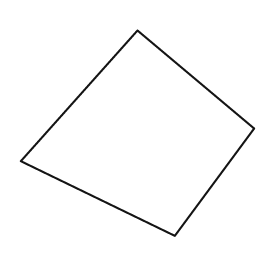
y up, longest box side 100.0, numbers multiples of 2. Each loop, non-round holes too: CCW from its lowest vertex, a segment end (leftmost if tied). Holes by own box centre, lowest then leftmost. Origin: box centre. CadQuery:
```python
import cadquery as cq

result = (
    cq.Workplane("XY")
    .moveTo(16.0, -44.0)
    .lineTo(50.0, 2.0)
    .lineTo(0.0, 44.0)
    .lineTo(-50.0, -12.0)
    .close()
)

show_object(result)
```